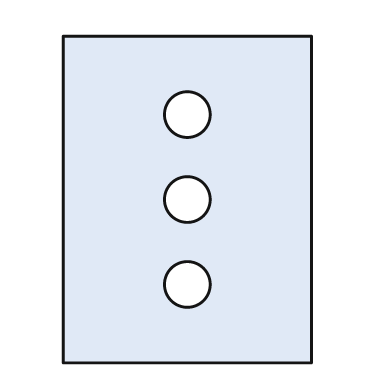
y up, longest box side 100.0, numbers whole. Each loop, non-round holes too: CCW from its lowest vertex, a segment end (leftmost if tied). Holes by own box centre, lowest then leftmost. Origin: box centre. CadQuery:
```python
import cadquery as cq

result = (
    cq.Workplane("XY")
    .moveTo(-38.0, -50.0)
    .lineTo(38.0, -50.0)
    .lineTo(38.0, 50.0)
    .lineTo(-38.0, 50.0)
    .close()
    .moveTo(0.0, -26.0)
    .circle(7.0)
    .moveTo(0.0, 0.0)
    .circle(7.0)
    .moveTo(0.0, 26.0)
    .circle(7.0)
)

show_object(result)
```